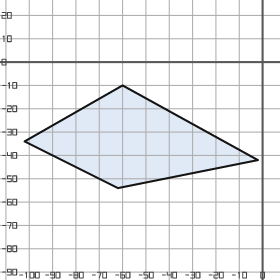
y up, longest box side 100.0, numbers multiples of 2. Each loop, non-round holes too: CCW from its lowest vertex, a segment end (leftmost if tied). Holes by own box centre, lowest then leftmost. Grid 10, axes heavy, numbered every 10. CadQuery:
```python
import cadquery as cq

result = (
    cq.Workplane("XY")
    .moveTo(-62.0, -54.0)
    .lineTo(-2.0, -42.0)
    .lineTo(-60.0, -10.0)
    .lineTo(-102.0, -34.0)
    .close()
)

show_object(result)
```